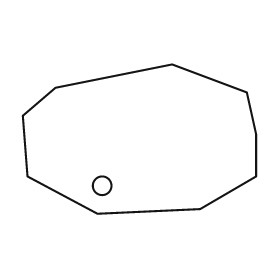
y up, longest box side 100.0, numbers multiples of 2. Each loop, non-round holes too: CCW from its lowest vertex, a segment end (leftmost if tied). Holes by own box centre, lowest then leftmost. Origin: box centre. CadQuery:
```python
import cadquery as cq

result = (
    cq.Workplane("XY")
    .moveTo(-18.0, -32.0)
    .lineTo(26.0, -30.0)
    .lineTo(50.0, -16.0)
    .lineTo(50.0, 2.0)
    .lineTo(46.0, 20.0)
    .lineTo(14.0, 32.0)
    .lineTo(-36.0, 22.0)
    .lineTo(-50.0, 10.0)
    .lineTo(-48.0, -16.0)
    .close()
    .moveTo(-16.0, -20.0)
    .circle(4.0)
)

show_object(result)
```